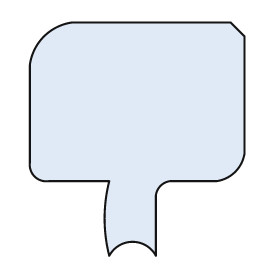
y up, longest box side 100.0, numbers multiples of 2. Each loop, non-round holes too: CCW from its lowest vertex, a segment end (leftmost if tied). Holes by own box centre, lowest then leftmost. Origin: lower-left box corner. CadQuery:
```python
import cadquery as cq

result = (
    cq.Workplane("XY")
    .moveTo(34.0, 0.0)
    .threePointArc((44.0, 6.0), (54.0, 0.0))
    .lineTo(54.0, 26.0)
    .threePointArc((56.0, 30.0), (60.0, 32.0))
    .lineTo(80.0, 32.0)
    .threePointArc((88.0, 36.0), (92.0, 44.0))
    .lineTo(92.0, 94.0)
    .lineTo(86.0, 100.0)
    .lineTo(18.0, 100.0)
    .threePointArc((6.0, 94.0), (0.0, 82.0))
    .lineTo(0.0, 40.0)
    .threePointArc((2.0, 34.0), (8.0, 32.0))
    .lineTo(34.0, 32.0)
    .threePointArc((32.0, 16.0), (34.0, 0.0))
    .close()
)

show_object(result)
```